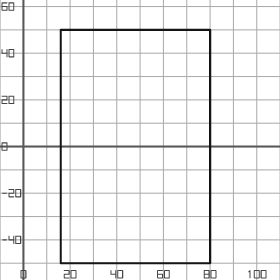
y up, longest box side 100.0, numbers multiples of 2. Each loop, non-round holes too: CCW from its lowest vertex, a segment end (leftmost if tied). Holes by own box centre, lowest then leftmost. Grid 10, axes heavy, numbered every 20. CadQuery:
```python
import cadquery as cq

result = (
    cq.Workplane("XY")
    .moveTo(16.0, -50.0)
    .lineTo(80.0, -50.0)
    .lineTo(80.0, 50.0)
    .lineTo(16.0, 50.0)
    .close()
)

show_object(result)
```